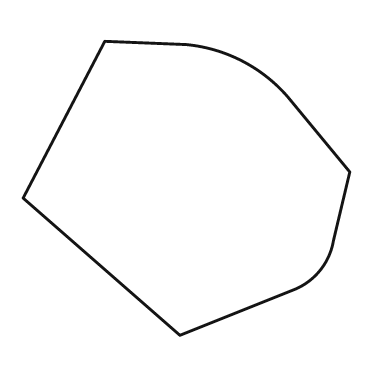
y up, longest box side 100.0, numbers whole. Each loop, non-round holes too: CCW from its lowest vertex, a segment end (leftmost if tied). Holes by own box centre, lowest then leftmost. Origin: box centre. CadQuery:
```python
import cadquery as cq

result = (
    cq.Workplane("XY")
    .moveTo(-2.0, -45.0)
    .lineTo(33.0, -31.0)
    .threePointArc((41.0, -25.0), (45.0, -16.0))
    .lineTo(50.0, 5.0)
    .lineTo(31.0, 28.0)
    .threePointArc((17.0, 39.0), (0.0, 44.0))
    .lineTo(-25.0, 45.0)
    .lineTo(-50.0, -3.0)
    .close()
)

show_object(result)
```